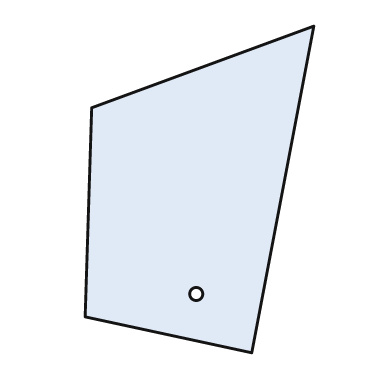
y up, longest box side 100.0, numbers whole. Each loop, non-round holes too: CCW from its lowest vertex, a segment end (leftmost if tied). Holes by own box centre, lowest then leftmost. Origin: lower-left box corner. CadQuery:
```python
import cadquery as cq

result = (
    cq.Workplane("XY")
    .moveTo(51.0, 0.0)
    .lineTo(70.0, 100.0)
    .lineTo(2.0, 75.0)
    .lineTo(0.0, 11.0)
    .close()
    .moveTo(34.0, 18.0)
    .circle(2.0)
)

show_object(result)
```